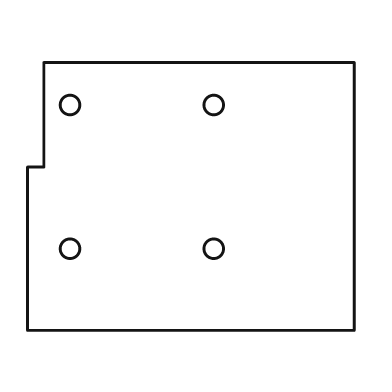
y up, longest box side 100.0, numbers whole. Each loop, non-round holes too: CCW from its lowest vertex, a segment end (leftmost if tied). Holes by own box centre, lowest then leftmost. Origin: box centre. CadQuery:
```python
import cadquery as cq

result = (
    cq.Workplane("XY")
    .moveTo(-50.0, -41.0)
    .lineTo(50.0, -41.0)
    .lineTo(50.0, 41.0)
    .lineTo(-45.0, 41.0)
    .lineTo(-45.0, 9.0)
    .lineTo(-50.0, 9.0)
    .close()
    .moveTo(-37.0, -16.0)
    .circle(3.0)
    .moveTo(7.0, -16.0)
    .circle(3.0)
    .moveTo(-37.0, 28.0)
    .circle(3.0)
    .moveTo(7.0, 28.0)
    .circle(3.0)
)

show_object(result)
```